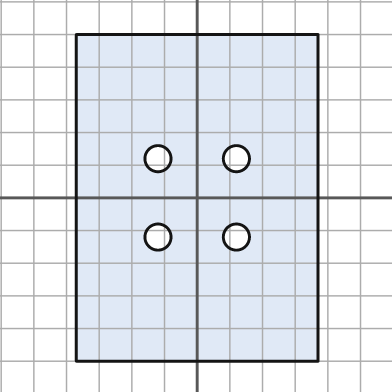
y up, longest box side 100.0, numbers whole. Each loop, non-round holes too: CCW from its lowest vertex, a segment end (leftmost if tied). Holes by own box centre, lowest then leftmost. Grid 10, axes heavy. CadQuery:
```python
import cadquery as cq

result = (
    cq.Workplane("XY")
    .moveTo(-37.0, -50.0)
    .lineTo(37.0, -50.0)
    .lineTo(37.0, 50.0)
    .lineTo(-37.0, 50.0)
    .close()
    .moveTo(-12.0, -12.0)
    .circle(4.0)
    .moveTo(12.0, -12.0)
    .circle(4.0)
    .moveTo(-12.0, 12.0)
    .circle(4.0)
    .moveTo(12.0, 12.0)
    .circle(4.0)
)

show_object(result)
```